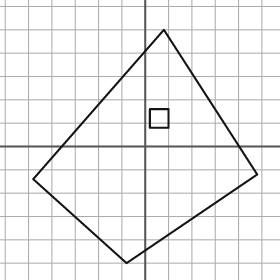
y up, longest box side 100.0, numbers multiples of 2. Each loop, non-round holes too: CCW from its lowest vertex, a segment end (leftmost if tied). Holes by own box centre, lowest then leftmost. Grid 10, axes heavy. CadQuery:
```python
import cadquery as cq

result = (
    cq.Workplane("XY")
    .moveTo(-8.0, -50.0)
    .lineTo(48.0, -12.0)
    .lineTo(8.0, 50.0)
    .lineTo(-48.0, -14.0)
    .close()
    .moveTo(2.0, 8.0)
    .lineTo(10.0, 8.0)
    .lineTo(10.0, 16.0)
    .lineTo(2.0, 16.0)
    .close()
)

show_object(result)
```